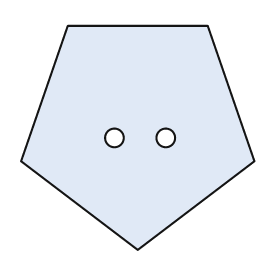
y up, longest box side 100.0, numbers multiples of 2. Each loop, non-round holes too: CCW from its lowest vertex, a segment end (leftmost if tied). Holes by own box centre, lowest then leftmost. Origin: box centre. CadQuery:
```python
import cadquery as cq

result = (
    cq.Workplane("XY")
    .moveTo(0.0, -48.0)
    .lineTo(50.0, -10.0)
    .lineTo(30.0, 48.0)
    .lineTo(-30.0, 48.0)
    .lineTo(-50.0, -10.0)
    .close()
    .moveTo(-10.0, 0.0)
    .circle(4.0)
    .moveTo(12.0, 0.0)
    .circle(4.0)
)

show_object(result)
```